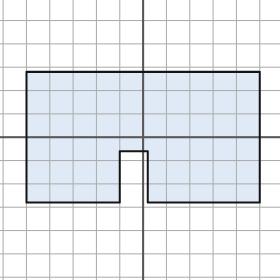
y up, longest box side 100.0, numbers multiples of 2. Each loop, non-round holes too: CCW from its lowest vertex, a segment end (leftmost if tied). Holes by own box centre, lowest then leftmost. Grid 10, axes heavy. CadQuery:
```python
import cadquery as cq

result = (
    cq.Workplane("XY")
    .moveTo(-50.0, -28.0)
    .lineTo(-10.0, -28.0)
    .lineTo(-10.0, -6.0)
    .lineTo(2.0, -6.0)
    .lineTo(2.0, -28.0)
    .lineTo(50.0, -28.0)
    .lineTo(50.0, 28.0)
    .lineTo(-50.0, 28.0)
    .close()
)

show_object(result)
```